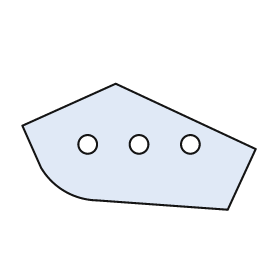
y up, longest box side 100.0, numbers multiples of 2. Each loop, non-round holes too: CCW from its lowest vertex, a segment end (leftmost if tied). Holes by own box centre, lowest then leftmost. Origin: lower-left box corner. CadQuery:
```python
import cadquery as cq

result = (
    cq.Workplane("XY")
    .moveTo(88.0, 0.0)
    .lineTo(100.0, 26.0)
    .lineTo(40.0, 54.0)
    .lineTo(0.0, 36.0)
    .lineTo(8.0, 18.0)
    .threePointArc((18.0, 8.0), (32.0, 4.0))
    .close()
    .moveTo(28.0, 28.0)
    .circle(4.0)
    .moveTo(50.0, 28.0)
    .circle(4.0)
    .moveTo(72.0, 28.0)
    .circle(4.0)
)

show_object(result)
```